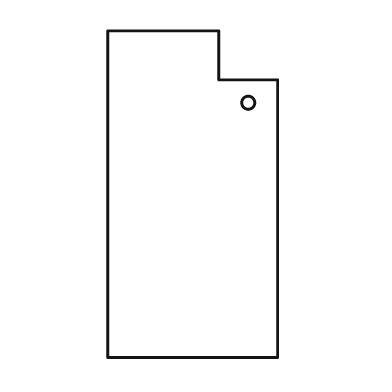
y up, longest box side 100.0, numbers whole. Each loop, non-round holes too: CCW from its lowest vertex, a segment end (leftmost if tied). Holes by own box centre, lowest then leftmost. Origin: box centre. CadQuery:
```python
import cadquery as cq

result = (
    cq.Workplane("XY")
    .moveTo(-26.0, -50.0)
    .lineTo(26.0, -50.0)
    .lineTo(26.0, 35.0)
    .lineTo(8.0, 35.0)
    .lineTo(8.0, 50.0)
    .lineTo(-26.0, 50.0)
    .close()
    .moveTo(17.0, 28.0)
    .circle(2.0)
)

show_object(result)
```